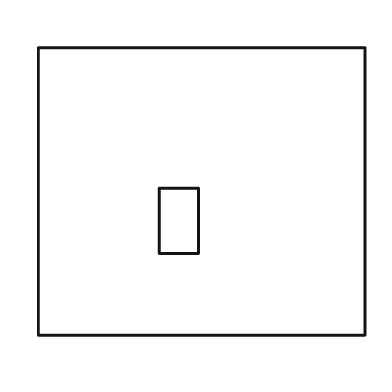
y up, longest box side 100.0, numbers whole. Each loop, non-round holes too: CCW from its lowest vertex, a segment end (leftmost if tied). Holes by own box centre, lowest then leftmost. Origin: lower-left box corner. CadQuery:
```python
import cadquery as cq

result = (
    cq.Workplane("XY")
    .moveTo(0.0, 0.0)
    .lineTo(100.0, 0.0)
    .lineTo(100.0, 88.0)
    .lineTo(0.0, 88.0)
    .close()
    .moveTo(37.0, 25.0)
    .lineTo(49.0, 25.0)
    .lineTo(49.0, 45.0)
    .lineTo(37.0, 45.0)
    .close()
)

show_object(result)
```